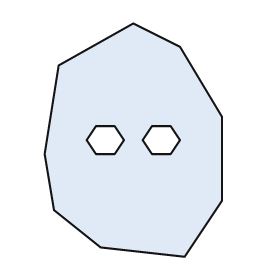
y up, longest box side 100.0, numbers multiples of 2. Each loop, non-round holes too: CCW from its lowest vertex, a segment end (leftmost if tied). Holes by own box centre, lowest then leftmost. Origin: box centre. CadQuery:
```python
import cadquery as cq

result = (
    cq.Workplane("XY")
    .moveTo(22.0, -50.0)
    .lineTo(38.0, -26.0)
    .lineTo(38.0, 10.0)
    .lineTo(20.0, 40.0)
    .lineTo(0.0, 50.0)
    .lineTo(-32.0, 32.0)
    .lineTo(-38.0, -6.0)
    .lineTo(-34.0, -30.0)
    .lineTo(-14.0, -46.0)
    .close()
    .moveTo(-16.0, -6.0)
    .lineTo(-8.0, -6.0)
    .lineTo(-4.0, 0.0)
    .lineTo(-8.0, 6.0)
    .lineTo(-16.0, 6.0)
    .lineTo(-20.0, 0.0)
    .close()
    .moveTo(8.0, -6.0)
    .lineTo(16.0, -6.0)
    .lineTo(20.0, 0.0)
    .lineTo(16.0, 6.0)
    .lineTo(8.0, 6.0)
    .lineTo(4.0, 0.0)
    .close()
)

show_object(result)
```